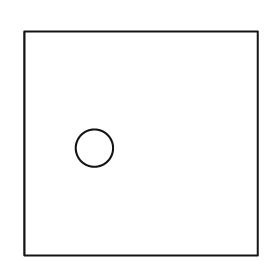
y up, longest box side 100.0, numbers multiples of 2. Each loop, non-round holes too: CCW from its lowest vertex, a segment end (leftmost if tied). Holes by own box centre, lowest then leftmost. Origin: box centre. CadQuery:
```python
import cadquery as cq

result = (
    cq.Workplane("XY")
    .moveTo(-50.0, -48.0)
    .lineTo(50.0, -48.0)
    .lineTo(50.0, 48.0)
    .lineTo(-50.0, 48.0)
    .close()
    .moveTo(-20.0, -2.0)
    .circle(8.0)
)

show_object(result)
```